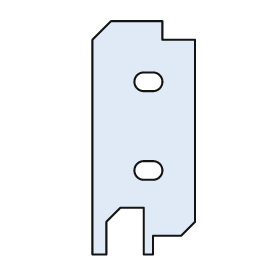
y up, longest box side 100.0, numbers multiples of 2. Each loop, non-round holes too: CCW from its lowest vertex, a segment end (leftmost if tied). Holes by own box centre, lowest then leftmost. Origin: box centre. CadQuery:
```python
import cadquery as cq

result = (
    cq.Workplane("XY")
    .moveTo(-22.0, -50.0)
    .lineTo(-16.0, -50.0)
    .lineTo(-16.0, -36.0)
    .lineTo(-10.0, -30.0)
    .lineTo(0.0, -30.0)
    .lineTo(0.0, -50.0)
    .lineTo(4.0, -50.0)
    .lineTo(4.0, -42.0)
    .lineTo(16.0, -42.0)
    .lineTo(22.0, -36.0)
    .lineTo(22.0, 42.0)
    .lineTo(8.0, 42.0)
    .lineTo(8.0, 50.0)
    .lineTo(-14.0, 50.0)
    .lineTo(-22.0, 42.0)
    .close()
    .moveTo(0.0, -18.0)
    .lineTo(4.0, -18.0)
    .threePointArc((8.0, -14.0), (4.0, -10.0))
    .lineTo(0.0, -10.0)
    .threePointArc((-4.0, -14.0), (0.0, -18.0))
    .close()
    .moveTo(0.0, 20.0)
    .lineTo(4.0, 20.0)
    .threePointArc((8.0, 24.0), (4.0, 28.0))
    .lineTo(0.0, 28.0)
    .threePointArc((-4.0, 24.0), (0.0, 20.0))
    .close()
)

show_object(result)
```